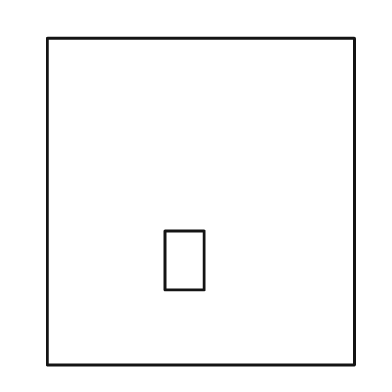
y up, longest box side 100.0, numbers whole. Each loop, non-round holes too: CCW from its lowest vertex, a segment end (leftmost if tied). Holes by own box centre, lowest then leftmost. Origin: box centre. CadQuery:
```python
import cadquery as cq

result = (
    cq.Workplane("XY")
    .moveTo(-47.0, -50.0)
    .lineTo(47.0, -50.0)
    .lineTo(47.0, 50.0)
    .lineTo(-47.0, 50.0)
    .close()
    .moveTo(-11.0, -27.0)
    .lineTo(1.0, -27.0)
    .lineTo(1.0, -9.0)
    .lineTo(-11.0, -9.0)
    .close()
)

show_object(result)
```